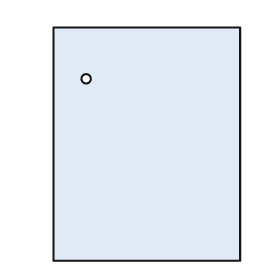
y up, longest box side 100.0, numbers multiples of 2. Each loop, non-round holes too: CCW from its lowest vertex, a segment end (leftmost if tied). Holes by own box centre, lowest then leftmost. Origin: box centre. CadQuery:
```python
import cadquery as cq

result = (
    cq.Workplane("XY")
    .moveTo(-40.0, -50.0)
    .lineTo(40.0, -50.0)
    .lineTo(40.0, 50.0)
    .lineTo(-40.0, 50.0)
    .close()
    .moveTo(-26.0, 28.0)
    .circle(2.0)
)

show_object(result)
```